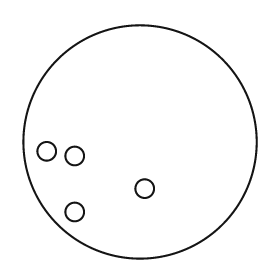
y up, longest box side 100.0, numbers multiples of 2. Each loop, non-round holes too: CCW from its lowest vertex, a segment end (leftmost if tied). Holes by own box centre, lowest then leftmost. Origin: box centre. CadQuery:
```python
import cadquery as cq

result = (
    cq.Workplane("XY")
    .moveTo(0.0, 0.0)
    .circle(50.0)
    .moveTo(-28.0, -30.0)
    .circle(4.0)
    .moveTo(2.0, -20.0)
    .circle(4.0)
    .moveTo(-28.0, -6.0)
    .circle(4.0)
    .moveTo(-40.0, -4.0)
    .circle(4.0)
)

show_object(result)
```